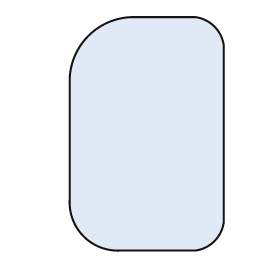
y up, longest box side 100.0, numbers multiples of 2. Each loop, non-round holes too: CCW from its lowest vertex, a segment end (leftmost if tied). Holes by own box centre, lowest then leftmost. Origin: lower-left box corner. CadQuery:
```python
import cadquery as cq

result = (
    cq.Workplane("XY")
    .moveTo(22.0, 0.0)
    .lineTo(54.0, 0.0)
    .threePointArc((62.0, 4.0), (66.0, 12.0))
    .lineTo(66.0, 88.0)
    .threePointArc((62.0, 96.0), (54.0, 100.0))
    .lineTo(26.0, 100.0)
    .threePointArc((8.0, 92.0), (0.0, 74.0))
    .lineTo(0.0, 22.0)
    .threePointArc((6.0, 6.0), (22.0, 0.0))
    .close()
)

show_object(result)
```